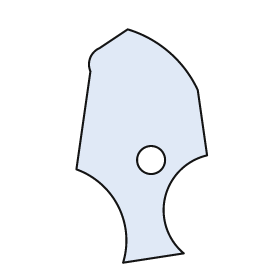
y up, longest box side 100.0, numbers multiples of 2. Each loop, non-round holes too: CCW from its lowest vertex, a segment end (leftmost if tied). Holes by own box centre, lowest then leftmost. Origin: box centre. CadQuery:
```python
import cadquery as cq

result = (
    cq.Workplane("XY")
    .moveTo(-8.0, -50.0)
    .lineTo(18.0, -46.0)
    .threePointArc((10.0, -22.0), (28.0, -4.0))
    .lineTo(24.0, 24.0)
    .threePointArc((12.0, 40.0), (-6.0, 50.0))
    .lineTo(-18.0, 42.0)
    .threePointArc((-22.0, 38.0), (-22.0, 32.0))
    .lineTo(-28.0, -10.0)
    .threePointArc((-10.0, -26.0), (-8.0, -50.0))
    .close()
    .moveTo(4.0, -6.0)
    .circle(6.0)
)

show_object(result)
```